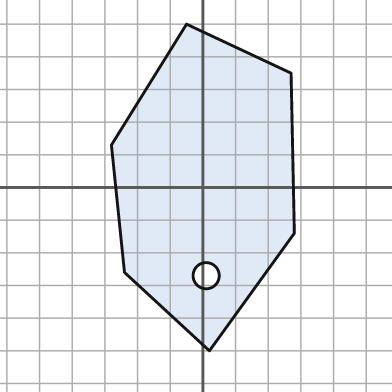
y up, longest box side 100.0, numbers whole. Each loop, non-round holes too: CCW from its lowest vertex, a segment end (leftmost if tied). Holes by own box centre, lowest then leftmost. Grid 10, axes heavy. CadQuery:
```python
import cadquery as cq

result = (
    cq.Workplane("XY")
    .moveTo(2.0, -50.0)
    .lineTo(28.0, -14.0)
    .lineTo(27.0, 35.0)
    .lineTo(-5.0, 50.0)
    .lineTo(-28.0, 13.0)
    .lineTo(-24.0, -26.0)
    .close()
    .moveTo(1.0, -27.0)
    .circle(4.0)
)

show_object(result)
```